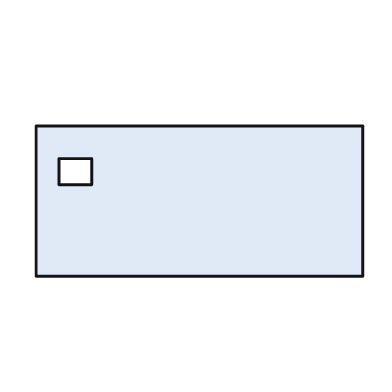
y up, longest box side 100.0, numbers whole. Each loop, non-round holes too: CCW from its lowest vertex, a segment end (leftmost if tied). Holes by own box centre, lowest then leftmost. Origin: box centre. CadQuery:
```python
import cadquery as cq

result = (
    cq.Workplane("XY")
    .moveTo(-50.0, -23.0)
    .lineTo(50.0, -23.0)
    .lineTo(50.0, 23.0)
    .lineTo(-50.0, 23.0)
    .close()
    .moveTo(-43.0, 5.0)
    .lineTo(-33.0, 5.0)
    .lineTo(-33.0, 13.0)
    .lineTo(-43.0, 13.0)
    .close()
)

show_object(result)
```